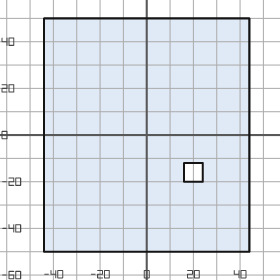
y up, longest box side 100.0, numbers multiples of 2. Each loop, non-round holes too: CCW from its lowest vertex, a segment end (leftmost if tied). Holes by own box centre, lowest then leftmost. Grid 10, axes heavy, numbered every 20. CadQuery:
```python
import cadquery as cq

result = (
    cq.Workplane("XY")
    .moveTo(-44.0, -50.0)
    .lineTo(44.0, -50.0)
    .lineTo(44.0, 50.0)
    .lineTo(-44.0, 50.0)
    .close()
    .moveTo(16.0, -20.0)
    .lineTo(24.0, -20.0)
    .lineTo(24.0, -12.0)
    .lineTo(16.0, -12.0)
    .close()
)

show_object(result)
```